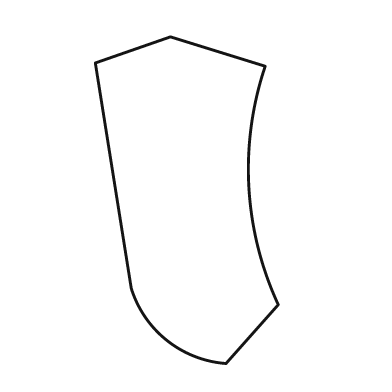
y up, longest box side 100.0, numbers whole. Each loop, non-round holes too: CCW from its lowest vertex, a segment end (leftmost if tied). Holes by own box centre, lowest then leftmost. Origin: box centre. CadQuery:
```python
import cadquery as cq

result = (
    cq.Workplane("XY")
    .moveTo(12.0, -50.0)
    .lineTo(28.0, -32.0)
    .threePointArc((19.0, 4.0), (24.0, 41.0))
    .lineTo(-5.0, 50.0)
    .lineTo(-28.0, 42.0)
    .lineTo(-17.0, -27.0)
    .threePointArc((-6.0, -43.0), (12.0, -50.0))
    .close()
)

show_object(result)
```